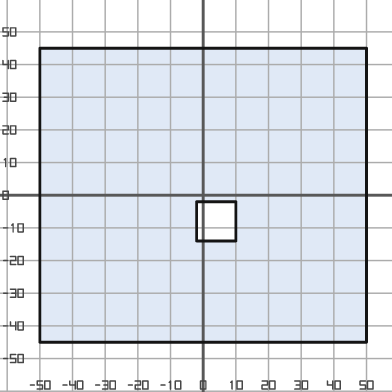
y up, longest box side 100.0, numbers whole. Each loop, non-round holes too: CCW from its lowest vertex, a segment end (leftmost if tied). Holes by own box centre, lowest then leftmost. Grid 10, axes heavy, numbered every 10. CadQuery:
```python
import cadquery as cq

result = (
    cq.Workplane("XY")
    .moveTo(-50.0, -45.0)
    .lineTo(50.0, -45.0)
    .lineTo(50.0, 45.0)
    .lineTo(-50.0, 45.0)
    .close()
    .moveTo(-2.0, -14.0)
    .lineTo(10.0, -14.0)
    .lineTo(10.0, -2.0)
    .lineTo(-2.0, -2.0)
    .close()
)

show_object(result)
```